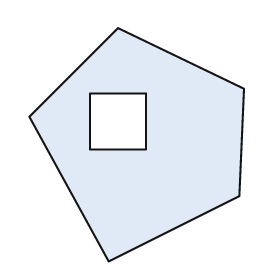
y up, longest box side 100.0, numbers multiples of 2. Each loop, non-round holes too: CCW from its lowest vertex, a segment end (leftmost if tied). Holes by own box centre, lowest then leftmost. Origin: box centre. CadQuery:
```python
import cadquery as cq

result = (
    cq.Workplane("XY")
    .moveTo(-12.0, -50.0)
    .lineTo(44.0, -22.0)
    .lineTo(46.0, 24.0)
    .lineTo(-8.0, 50.0)
    .lineTo(-46.0, 12.0)
    .close()
    .moveTo(-20.0, -2.0)
    .lineTo(4.0, -2.0)
    .lineTo(4.0, 22.0)
    .lineTo(-20.0, 22.0)
    .close()
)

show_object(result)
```